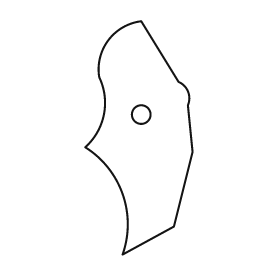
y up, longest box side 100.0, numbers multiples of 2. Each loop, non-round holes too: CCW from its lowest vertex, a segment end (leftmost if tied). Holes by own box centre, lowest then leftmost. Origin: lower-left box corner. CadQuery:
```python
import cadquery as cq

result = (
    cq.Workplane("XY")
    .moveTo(16.0, 0.0)
    .lineTo(38.0, 12.0)
    .lineTo(46.0, 44.0)
    .lineTo(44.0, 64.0)
    .threePointArc((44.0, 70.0), (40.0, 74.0))
    .lineTo(24.0, 100.0)
    .threePointArc((10.0, 92.0), (6.0, 76.0))
    .threePointArc((8.0, 60.0), (0.0, 46.0))
    .threePointArc((16.0, 26.0), (16.0, 0.0))
    .close()
    .moveTo(24.0, 60.0)
    .circle(4.0)
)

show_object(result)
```